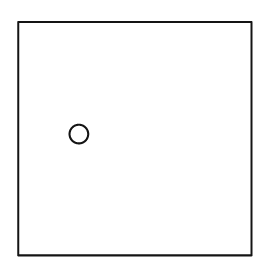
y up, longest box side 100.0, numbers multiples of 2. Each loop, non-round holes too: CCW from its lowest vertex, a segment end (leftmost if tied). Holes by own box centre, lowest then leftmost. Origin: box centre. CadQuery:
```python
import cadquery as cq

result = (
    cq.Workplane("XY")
    .moveTo(-50.0, -50.0)
    .lineTo(50.0, -50.0)
    .lineTo(50.0, 50.0)
    .lineTo(-50.0, 50.0)
    .close()
    .moveTo(-24.0, 2.0)
    .circle(4.0)
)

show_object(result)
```